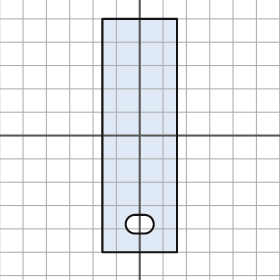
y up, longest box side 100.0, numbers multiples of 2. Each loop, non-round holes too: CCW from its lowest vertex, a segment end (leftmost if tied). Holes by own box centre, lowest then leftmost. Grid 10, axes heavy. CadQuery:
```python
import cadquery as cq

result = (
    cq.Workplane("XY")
    .moveTo(-16.0, -50.0)
    .lineTo(16.0, -50.0)
    .lineTo(16.0, 50.0)
    .lineTo(-16.0, 50.0)
    .close()
    .moveTo(-2.0, -42.0)
    .lineTo(2.0, -42.0)
    .threePointArc((6.0, -38.0), (2.0, -34.0))
    .lineTo(-2.0, -34.0)
    .threePointArc((-6.0, -38.0), (-2.0, -42.0))
    .close()
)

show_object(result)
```